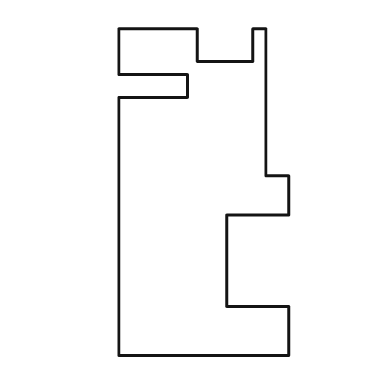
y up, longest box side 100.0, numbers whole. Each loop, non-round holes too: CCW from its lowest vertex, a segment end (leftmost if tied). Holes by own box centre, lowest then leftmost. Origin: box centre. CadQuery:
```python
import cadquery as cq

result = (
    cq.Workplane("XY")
    .moveTo(-26.0, -50.0)
    .lineTo(26.0, -50.0)
    .lineTo(26.0, -35.0)
    .lineTo(7.0, -35.0)
    .lineTo(7.0, -7.0)
    .lineTo(26.0, -7.0)
    .lineTo(26.0, 5.0)
    .lineTo(19.0, 5.0)
    .lineTo(19.0, 50.0)
    .lineTo(15.0, 50.0)
    .lineTo(15.0, 40.0)
    .lineTo(-2.0, 40.0)
    .lineTo(-2.0, 50.0)
    .lineTo(-26.0, 50.0)
    .lineTo(-26.0, 36.0)
    .lineTo(-5.0, 36.0)
    .lineTo(-5.0, 29.0)
    .lineTo(-26.0, 29.0)
    .close()
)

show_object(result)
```